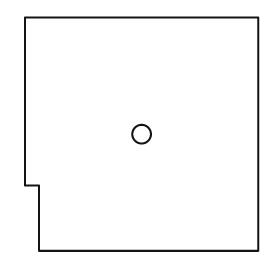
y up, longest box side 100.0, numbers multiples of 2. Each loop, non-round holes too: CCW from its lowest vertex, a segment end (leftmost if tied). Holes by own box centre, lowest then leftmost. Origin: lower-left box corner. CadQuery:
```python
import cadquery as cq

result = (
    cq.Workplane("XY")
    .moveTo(6.0, 0.0)
    .lineTo(100.0, 0.0)
    .lineTo(100.0, 100.0)
    .lineTo(0.0, 100.0)
    .lineTo(0.0, 28.0)
    .lineTo(6.0, 28.0)
    .close()
    .moveTo(50.0, 50.0)
    .circle(4.0)
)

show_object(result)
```